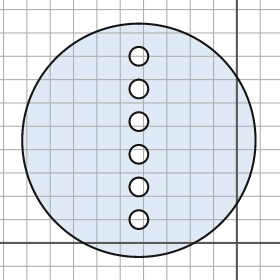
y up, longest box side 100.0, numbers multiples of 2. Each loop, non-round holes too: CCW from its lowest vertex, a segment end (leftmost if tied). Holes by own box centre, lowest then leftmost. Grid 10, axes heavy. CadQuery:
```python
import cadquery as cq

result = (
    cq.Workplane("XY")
    .moveTo(-42.0, 44.0)
    .circle(50.0)
    .moveTo(-42.0, 10.0)
    .circle(4.0)
    .moveTo(-42.0, 24.0)
    .circle(4.0)
    .moveTo(-42.0, 38.0)
    .circle(4.0)
    .moveTo(-42.0, 52.0)
    .circle(4.0)
    .moveTo(-42.0, 66.0)
    .circle(4.0)
    .moveTo(-42.0, 80.0)
    .circle(4.0)
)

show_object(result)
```